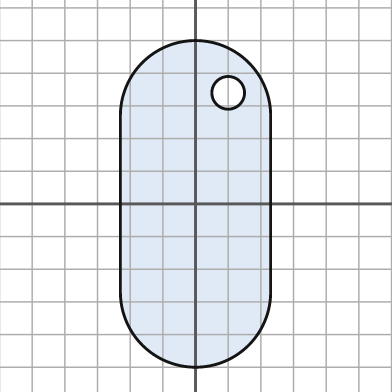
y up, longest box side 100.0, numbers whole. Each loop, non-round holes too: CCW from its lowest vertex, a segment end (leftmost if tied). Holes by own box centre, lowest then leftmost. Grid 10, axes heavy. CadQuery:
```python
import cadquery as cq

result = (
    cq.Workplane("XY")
    .moveTo(-23.0, -27.0)
    .threePointArc((0.0, -50.0), (23.0, -27.0))
    .lineTo(23.0, 27.0)
    .threePointArc((0.0, 50.0), (-23.0, 27.0))
    .close()
    .moveTo(10.0, 34.0)
    .circle(5.0)
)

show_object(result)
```